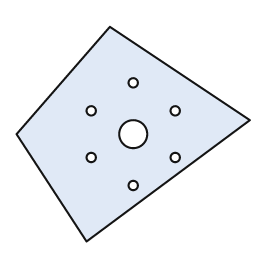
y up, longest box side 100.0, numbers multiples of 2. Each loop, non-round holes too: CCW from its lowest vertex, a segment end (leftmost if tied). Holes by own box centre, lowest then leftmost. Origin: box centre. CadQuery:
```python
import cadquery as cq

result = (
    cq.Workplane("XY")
    .moveTo(-20.0, -46.0)
    .lineTo(50.0, 6.0)
    .lineTo(-10.0, 46.0)
    .lineTo(-50.0, 0.0)
    .close()
    .moveTo(0.0, -22.0)
    .circle(2.0)
    .moveTo(-18.0, -10.0)
    .circle(2.0)
    .moveTo(18.0, -10.0)
    .circle(2.0)
    .moveTo(0.0, 0.0)
    .circle(6.0)
    .moveTo(-18.0, 10.0)
    .circle(2.0)
    .moveTo(18.0, 10.0)
    .circle(2.0)
    .moveTo(0.0, 22.0)
    .circle(2.0)
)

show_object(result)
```